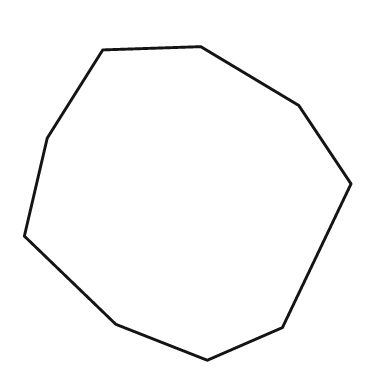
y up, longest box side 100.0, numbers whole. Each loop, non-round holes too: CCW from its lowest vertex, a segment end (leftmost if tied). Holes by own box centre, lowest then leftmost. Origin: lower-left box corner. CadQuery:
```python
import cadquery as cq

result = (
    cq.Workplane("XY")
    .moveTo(56.0, 0.0)
    .lineTo(79.0, 10.0)
    .lineTo(100.0, 54.0)
    .lineTo(84.0, 78.0)
    .lineTo(54.0, 96.0)
    .lineTo(24.0, 95.0)
    .lineTo(7.0, 68.0)
    .lineTo(0.0, 38.0)
    .lineTo(28.0, 11.0)
    .close()
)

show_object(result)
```